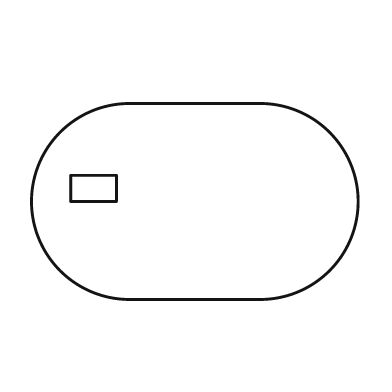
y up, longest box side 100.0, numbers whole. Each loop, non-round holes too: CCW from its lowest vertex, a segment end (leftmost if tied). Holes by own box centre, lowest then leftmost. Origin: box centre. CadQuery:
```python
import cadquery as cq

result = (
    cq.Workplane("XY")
    .moveTo(-20.0, -30.0)
    .lineTo(20.0, -30.0)
    .threePointArc((50.0, 0.0), (20.0, 30.0))
    .lineTo(-20.0, 30.0)
    .threePointArc((-50.0, 0.0), (-20.0, -30.0))
    .close()
    .moveTo(-38.0, 0.0)
    .lineTo(-24.0, 0.0)
    .lineTo(-24.0, 8.0)
    .lineTo(-38.0, 8.0)
    .close()
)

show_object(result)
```